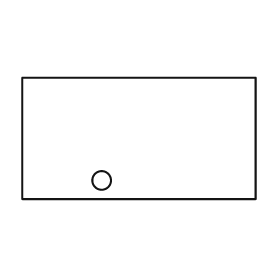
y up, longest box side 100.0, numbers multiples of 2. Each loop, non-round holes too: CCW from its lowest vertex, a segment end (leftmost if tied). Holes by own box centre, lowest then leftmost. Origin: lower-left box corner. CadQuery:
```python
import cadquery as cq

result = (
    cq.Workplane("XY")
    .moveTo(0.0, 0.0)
    .lineTo(100.0, 0.0)
    .lineTo(100.0, 52.0)
    .lineTo(0.0, 52.0)
    .close()
    .moveTo(34.0, 8.0)
    .circle(4.0)
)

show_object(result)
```